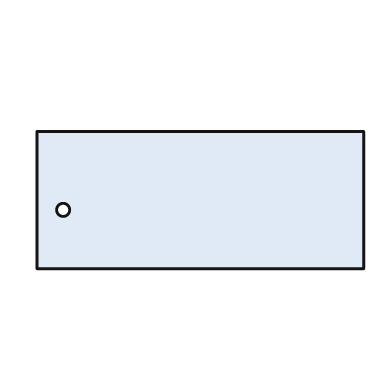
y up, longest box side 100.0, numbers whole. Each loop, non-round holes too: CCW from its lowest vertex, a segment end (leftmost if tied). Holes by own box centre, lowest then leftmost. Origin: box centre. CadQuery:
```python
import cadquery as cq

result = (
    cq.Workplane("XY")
    .moveTo(-50.0, -21.0)
    .lineTo(50.0, -21.0)
    .lineTo(50.0, 21.0)
    .lineTo(-50.0, 21.0)
    .close()
    .moveTo(-42.0, -3.0)
    .circle(2.0)
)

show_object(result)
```